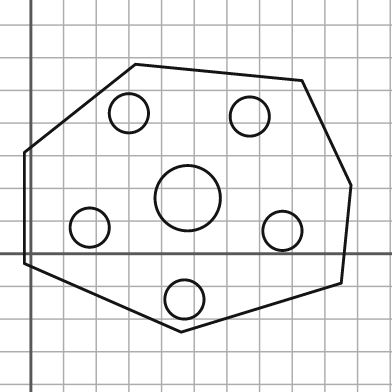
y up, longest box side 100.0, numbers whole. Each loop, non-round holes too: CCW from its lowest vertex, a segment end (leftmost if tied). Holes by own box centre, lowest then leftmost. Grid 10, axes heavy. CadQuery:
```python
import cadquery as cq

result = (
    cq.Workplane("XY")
    .moveTo(46.0, -24.0)
    .lineTo(95.0, -9.0)
    .lineTo(98.0, 21.0)
    .lineTo(83.0, 53.0)
    .lineTo(32.0, 58.0)
    .lineTo(-2.0, 31.0)
    .lineTo(-2.0, -3.0)
    .close()
    .moveTo(47.0, -14.0)
    .circle(6.0)
    .moveTo(77.0, 7.0)
    .circle(6.0)
    .moveTo(18.0, 8.0)
    .circle(6.0)
    .moveTo(48.0, 17.0)
    .circle(10.0)
    .moveTo(67.0, 42.0)
    .circle(6.0)
    .moveTo(30.0, 43.0)
    .circle(6.0)
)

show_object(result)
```